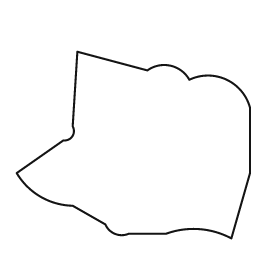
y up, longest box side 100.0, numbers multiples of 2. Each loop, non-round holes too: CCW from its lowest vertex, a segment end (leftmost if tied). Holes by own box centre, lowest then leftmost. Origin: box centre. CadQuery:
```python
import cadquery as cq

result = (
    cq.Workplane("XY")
    .moveTo(42.0, -40.0)
    .lineTo(50.0, -12.0)
    .lineTo(50.0, 16.0)
    .threePointArc((40.0, 28.0), (24.0, 28.0))
    .threePointArc((16.0, 34.0), (6.0, 32.0))
    .lineTo(-24.0, 40.0)
    .lineTo(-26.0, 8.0)
    .threePointArc((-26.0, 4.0), (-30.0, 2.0))
    .lineTo(-50.0, -12.0)
    .threePointArc((-40.0, -22.0), (-26.0, -26.0))
    .lineTo(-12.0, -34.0)
    .threePointArc((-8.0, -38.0), (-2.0, -38.0))
    .lineTo(14.0, -38.0)
    .threePointArc((28.0, -36.0), (42.0, -40.0))
    .close()
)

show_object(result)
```